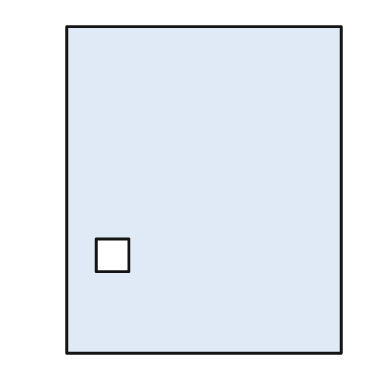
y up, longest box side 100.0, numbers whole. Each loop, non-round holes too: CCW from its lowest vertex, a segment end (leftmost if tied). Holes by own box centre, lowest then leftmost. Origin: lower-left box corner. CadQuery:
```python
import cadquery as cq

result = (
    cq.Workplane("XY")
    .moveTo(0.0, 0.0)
    .lineTo(84.0, 0.0)
    .lineTo(84.0, 100.0)
    .lineTo(0.0, 100.0)
    .close()
    .moveTo(9.0, 25.0)
    .lineTo(19.0, 25.0)
    .lineTo(19.0, 35.0)
    .lineTo(9.0, 35.0)
    .close()
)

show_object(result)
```